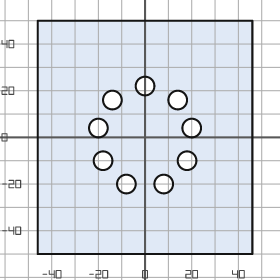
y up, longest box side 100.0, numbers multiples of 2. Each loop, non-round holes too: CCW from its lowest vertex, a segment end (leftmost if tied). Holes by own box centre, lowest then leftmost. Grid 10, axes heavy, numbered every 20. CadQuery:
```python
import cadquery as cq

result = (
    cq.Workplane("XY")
    .moveTo(-46.0, -50.0)
    .lineTo(46.0, -50.0)
    .lineTo(46.0, 50.0)
    .lineTo(-46.0, 50.0)
    .close()
    .moveTo(-8.0, -20.0)
    .circle(4.0)
    .moveTo(8.0, -20.0)
    .circle(4.0)
    .moveTo(-18.0, -10.0)
    .circle(4.0)
    .moveTo(18.0, -10.0)
    .circle(4.0)
    .moveTo(-20.0, 4.0)
    .circle(4.0)
    .moveTo(20.0, 4.0)
    .circle(4.0)
    .moveTo(-14.0, 16.0)
    .circle(4.0)
    .moveTo(14.0, 16.0)
    .circle(4.0)
    .moveTo(0.0, 22.0)
    .circle(4.0)
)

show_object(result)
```